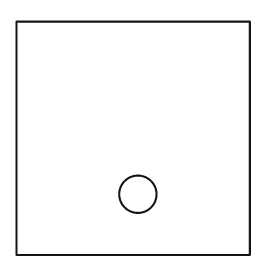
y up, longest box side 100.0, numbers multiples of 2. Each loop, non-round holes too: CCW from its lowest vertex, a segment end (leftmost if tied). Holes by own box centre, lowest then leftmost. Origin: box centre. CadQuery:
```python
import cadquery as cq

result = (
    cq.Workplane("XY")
    .moveTo(-50.0, -50.0)
    .lineTo(50.0, -50.0)
    .lineTo(50.0, 50.0)
    .lineTo(-50.0, 50.0)
    .close()
    .moveTo(2.0, -24.0)
    .circle(8.0)
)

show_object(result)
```